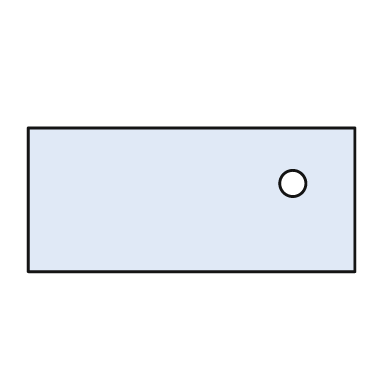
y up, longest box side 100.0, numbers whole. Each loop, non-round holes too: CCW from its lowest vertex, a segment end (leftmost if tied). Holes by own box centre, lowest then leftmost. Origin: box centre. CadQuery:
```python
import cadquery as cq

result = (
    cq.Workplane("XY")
    .moveTo(-50.0, -22.0)
    .lineTo(50.0, -22.0)
    .lineTo(50.0, 22.0)
    .lineTo(-50.0, 22.0)
    .close()
    .moveTo(31.0, 5.0)
    .circle(4.0)
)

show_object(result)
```